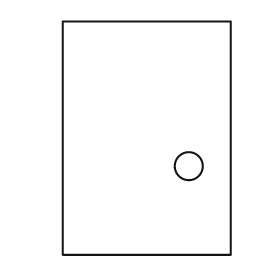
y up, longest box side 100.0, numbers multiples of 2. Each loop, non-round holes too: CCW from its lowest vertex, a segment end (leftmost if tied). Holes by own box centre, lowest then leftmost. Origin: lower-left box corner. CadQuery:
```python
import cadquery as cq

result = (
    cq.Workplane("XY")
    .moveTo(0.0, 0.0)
    .lineTo(72.0, 0.0)
    .lineTo(72.0, 100.0)
    .lineTo(0.0, 100.0)
    .close()
    .moveTo(54.0, 38.0)
    .circle(6.0)
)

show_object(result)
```